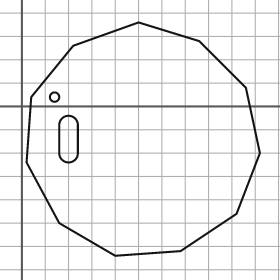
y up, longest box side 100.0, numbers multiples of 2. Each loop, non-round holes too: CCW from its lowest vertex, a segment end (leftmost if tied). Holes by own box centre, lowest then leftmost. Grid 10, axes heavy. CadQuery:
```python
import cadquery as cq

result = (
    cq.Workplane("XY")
    .moveTo(40.0, -64.0)
    .lineTo(68.0, -62.0)
    .lineTo(92.0, -46.0)
    .lineTo(102.0, -20.0)
    .lineTo(96.0, 8.0)
    .lineTo(76.0, 28.0)
    .lineTo(50.0, 36.0)
    .lineTo(22.0, 26.0)
    .lineTo(4.0, 4.0)
    .lineTo(2.0, -24.0)
    .lineTo(16.0, -50.0)
    .close()
    .moveTo(16.0, -20.0)
    .threePointArc((20.0, -24.0), (24.0, -20.0))
    .lineTo(24.0, -8.0)
    .threePointArc((20.0, -4.0), (16.0, -8.0))
    .close()
    .moveTo(14.0, 4.0)
    .circle(2.0)
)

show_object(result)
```